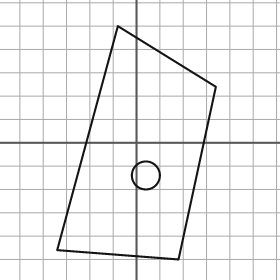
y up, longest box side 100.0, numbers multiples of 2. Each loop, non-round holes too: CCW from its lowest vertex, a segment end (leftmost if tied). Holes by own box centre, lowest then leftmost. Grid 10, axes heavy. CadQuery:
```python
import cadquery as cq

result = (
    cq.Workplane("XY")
    .moveTo(18.0, -50.0)
    .lineTo(34.0, 24.0)
    .lineTo(-8.0, 50.0)
    .lineTo(-34.0, -46.0)
    .close()
    .moveTo(4.0, -14.0)
    .circle(6.0)
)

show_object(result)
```